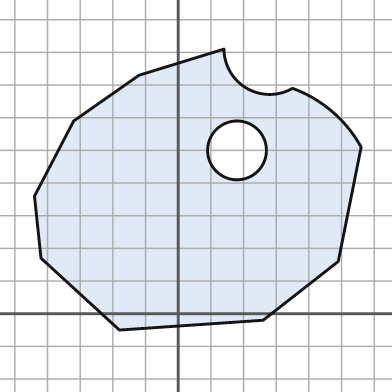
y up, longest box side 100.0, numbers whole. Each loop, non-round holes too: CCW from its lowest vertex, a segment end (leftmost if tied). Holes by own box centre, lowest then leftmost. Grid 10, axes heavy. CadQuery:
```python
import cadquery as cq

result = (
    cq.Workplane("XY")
    .moveTo(-18.0, -5.0)
    .lineTo(26.0, -2.0)
    .lineTo(49.0, 16.0)
    .lineTo(56.0, 51.0)
    .threePointArc((47.0, 62.0), (35.0, 69.0))
    .threePointArc((21.0, 69.0), (14.0, 81.0))
    .lineTo(-12.0, 73.0)
    .lineTo(-32.0, 59.0)
    .lineTo(-44.0, 36.0)
    .lineTo(-42.0, 17.0)
    .close()
    .moveTo(18.0, 50.0)
    .circle(9.0)
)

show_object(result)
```